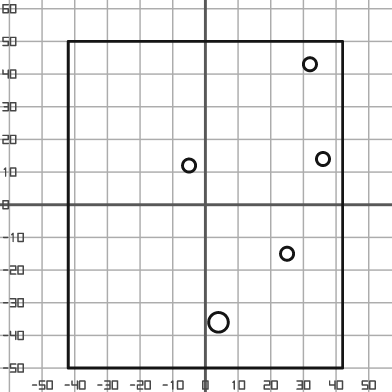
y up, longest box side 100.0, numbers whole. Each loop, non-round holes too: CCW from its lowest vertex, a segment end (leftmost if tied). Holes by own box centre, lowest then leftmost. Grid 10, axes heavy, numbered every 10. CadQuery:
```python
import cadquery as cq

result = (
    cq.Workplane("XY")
    .moveTo(-42.0, -50.0)
    .lineTo(42.0, -50.0)
    .lineTo(42.0, 50.0)
    .lineTo(-42.0, 50.0)
    .close()
    .moveTo(4.0, -36.0)
    .circle(3.0)
    .moveTo(25.0, -15.0)
    .circle(2.0)
    .moveTo(-5.0, 12.0)
    .circle(2.0)
    .moveTo(36.0, 14.0)
    .circle(2.0)
    .moveTo(32.0, 43.0)
    .circle(2.0)
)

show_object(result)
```